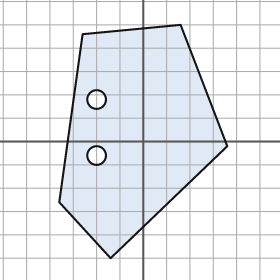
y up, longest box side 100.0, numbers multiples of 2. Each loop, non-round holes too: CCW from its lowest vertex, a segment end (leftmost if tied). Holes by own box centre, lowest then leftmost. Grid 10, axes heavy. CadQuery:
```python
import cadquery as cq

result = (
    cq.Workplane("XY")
    .moveTo(-14.0, -50.0)
    .lineTo(36.0, -2.0)
    .lineTo(16.0, 50.0)
    .lineTo(-26.0, 46.0)
    .lineTo(-36.0, -26.0)
    .close()
    .moveTo(-20.0, -6.0)
    .circle(4.0)
    .moveTo(-20.0, 18.0)
    .circle(4.0)
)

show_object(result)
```